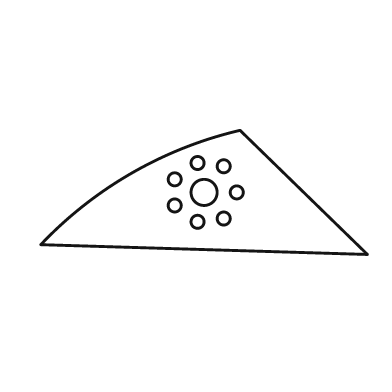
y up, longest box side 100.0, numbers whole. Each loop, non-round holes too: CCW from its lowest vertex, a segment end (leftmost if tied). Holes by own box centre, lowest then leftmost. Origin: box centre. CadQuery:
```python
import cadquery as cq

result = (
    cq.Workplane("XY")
    .moveTo(50.0, -19.0)
    .lineTo(11.0, 19.0)
    .threePointArc((-22.0, 6.0), (-50.0, -16.0))
    .close()
    .moveTo(-2.0, -9.0)
    .circle(2.0)
    .moveTo(6.0, -8.0)
    .circle(2.0)
    .moveTo(-9.0, -4.0)
    .circle(2.0)
    .moveTo(0.0, 0.0)
    .circle(4.0)
    .moveTo(10.0, 0.0)
    .circle(2.0)
    .moveTo(-9.0, 4.0)
    .circle(2.0)
    .moveTo(6.0, 8.0)
    .circle(2.0)
    .moveTo(-2.0, 9.0)
    .circle(2.0)
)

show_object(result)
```